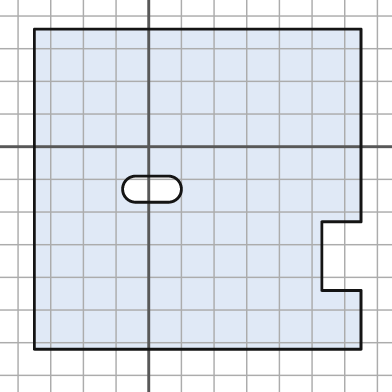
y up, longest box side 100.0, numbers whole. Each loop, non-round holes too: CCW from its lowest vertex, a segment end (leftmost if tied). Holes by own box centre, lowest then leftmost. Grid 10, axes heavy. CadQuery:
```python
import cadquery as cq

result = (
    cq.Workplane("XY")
    .moveTo(-35.0, -62.0)
    .lineTo(65.0, -62.0)
    .lineTo(65.0, -44.0)
    .lineTo(53.0, -44.0)
    .lineTo(53.0, -23.0)
    .lineTo(65.0, -23.0)
    .lineTo(65.0, 36.0)
    .lineTo(-35.0, 36.0)
    .close()
    .moveTo(-4.0, -17.0)
    .lineTo(6.0, -17.0)
    .threePointArc((10.0, -13.0), (6.0, -9.0))
    .lineTo(-4.0, -9.0)
    .threePointArc((-8.0, -13.0), (-4.0, -17.0))
    .close()
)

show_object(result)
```